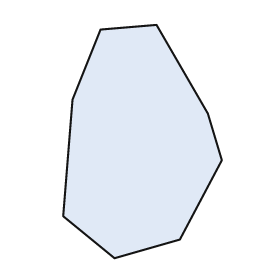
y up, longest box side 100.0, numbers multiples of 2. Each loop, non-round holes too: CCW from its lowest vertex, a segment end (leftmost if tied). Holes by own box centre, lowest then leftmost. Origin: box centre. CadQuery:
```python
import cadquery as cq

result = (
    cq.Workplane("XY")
    .moveTo(-12.0, -50.0)
    .lineTo(16.0, -42.0)
    .lineTo(34.0, -8.0)
    .lineTo(28.0, 12.0)
    .lineTo(6.0, 50.0)
    .lineTo(-18.0, 48.0)
    .lineTo(-30.0, 18.0)
    .lineTo(-34.0, -32.0)
    .close()
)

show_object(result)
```